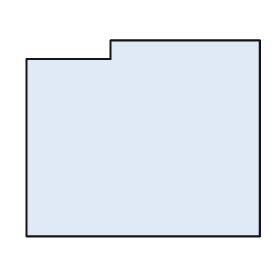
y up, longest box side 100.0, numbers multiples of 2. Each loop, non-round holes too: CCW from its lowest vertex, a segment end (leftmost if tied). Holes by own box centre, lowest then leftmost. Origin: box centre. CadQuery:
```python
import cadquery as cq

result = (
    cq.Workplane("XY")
    .moveTo(-50.0, -42.0)
    .lineTo(50.0, -42.0)
    .lineTo(50.0, 42.0)
    .lineTo(-14.0, 42.0)
    .lineTo(-14.0, 34.0)
    .lineTo(-50.0, 34.0)
    .close()
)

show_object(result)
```